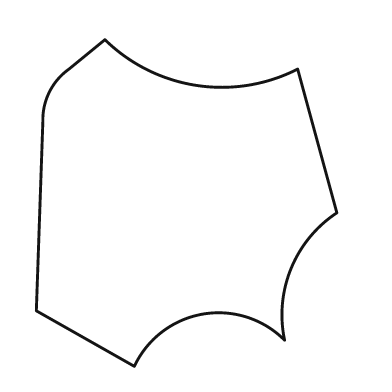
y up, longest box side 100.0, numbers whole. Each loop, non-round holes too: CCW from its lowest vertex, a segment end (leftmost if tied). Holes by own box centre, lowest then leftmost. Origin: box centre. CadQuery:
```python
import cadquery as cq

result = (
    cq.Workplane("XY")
    .moveTo(-16.0, -50.0)
    .threePointArc((5.0, -34.0), (30.0, -42.0))
    .threePointArc((32.0, -20.0), (46.0, -3.0))
    .lineTo(34.0, 41.0)
    .threePointArc((3.0, 36.0), (-25.0, 50.0))
    .lineTo(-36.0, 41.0)
    .threePointArc((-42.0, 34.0), (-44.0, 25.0))
    .lineTo(-46.0, -33.0)
    .close()
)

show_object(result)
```